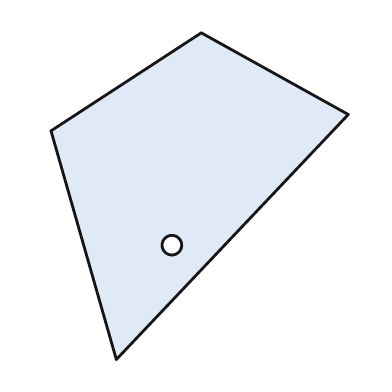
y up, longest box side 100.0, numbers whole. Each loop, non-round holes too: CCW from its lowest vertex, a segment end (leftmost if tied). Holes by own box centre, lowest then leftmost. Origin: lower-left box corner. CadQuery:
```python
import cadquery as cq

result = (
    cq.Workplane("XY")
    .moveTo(20.0, 0.0)
    .lineTo(91.0, 75.0)
    .lineTo(46.0, 100.0)
    .lineTo(0.0, 70.0)
    .close()
    .moveTo(37.0, 35.0)
    .circle(3.0)
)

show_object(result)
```